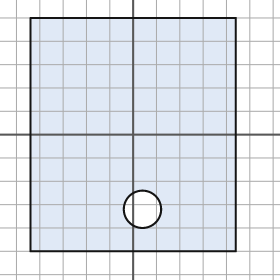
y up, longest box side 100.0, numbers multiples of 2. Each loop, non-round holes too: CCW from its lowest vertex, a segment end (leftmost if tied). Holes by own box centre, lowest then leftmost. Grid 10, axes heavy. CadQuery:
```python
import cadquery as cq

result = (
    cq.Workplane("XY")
    .moveTo(-44.0, -50.0)
    .lineTo(44.0, -50.0)
    .lineTo(44.0, 50.0)
    .lineTo(-44.0, 50.0)
    .close()
    .moveTo(4.0, -32.0)
    .circle(8.0)
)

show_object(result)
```